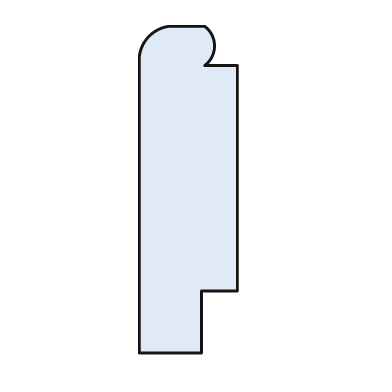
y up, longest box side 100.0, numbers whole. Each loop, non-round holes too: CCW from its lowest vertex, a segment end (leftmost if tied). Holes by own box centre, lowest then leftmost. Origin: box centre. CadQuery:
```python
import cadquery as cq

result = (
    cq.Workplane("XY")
    .moveTo(-15.0, -50.0)
    .lineTo(4.0, -50.0)
    .lineTo(4.0, -31.0)
    .lineTo(15.0, -31.0)
    .lineTo(15.0, 38.0)
    .lineTo(5.0, 38.0)
    .threePointArc((8.0, 44.0), (5.0, 50.0))
    .lineTo(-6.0, 50.0)
    .threePointArc((-12.0, 47.0), (-15.0, 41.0))
    .close()
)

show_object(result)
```